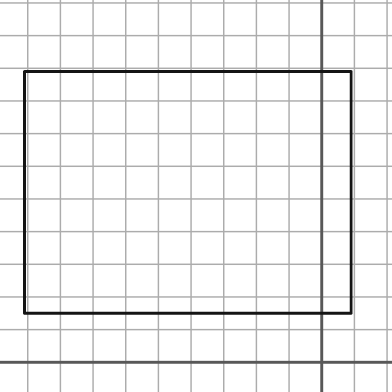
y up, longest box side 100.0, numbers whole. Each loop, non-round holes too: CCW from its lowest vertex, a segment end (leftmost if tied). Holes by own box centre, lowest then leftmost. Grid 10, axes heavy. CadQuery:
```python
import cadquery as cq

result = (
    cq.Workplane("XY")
    .moveTo(-91.0, 15.0)
    .lineTo(9.0, 15.0)
    .lineTo(9.0, 89.0)
    .lineTo(-91.0, 89.0)
    .close()
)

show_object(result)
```